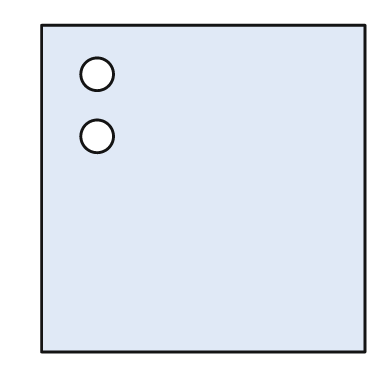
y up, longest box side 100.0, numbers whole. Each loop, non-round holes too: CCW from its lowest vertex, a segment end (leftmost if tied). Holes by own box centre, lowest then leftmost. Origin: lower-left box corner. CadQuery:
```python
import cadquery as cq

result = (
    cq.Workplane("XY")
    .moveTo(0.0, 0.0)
    .lineTo(99.0, 0.0)
    .lineTo(99.0, 100.0)
    .lineTo(0.0, 100.0)
    .close()
    .moveTo(17.0, 66.0)
    .circle(5.0)
    .moveTo(17.0, 85.0)
    .circle(5.0)
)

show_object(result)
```